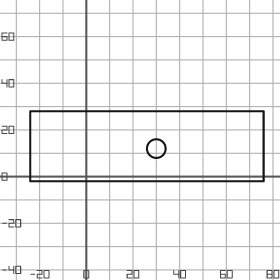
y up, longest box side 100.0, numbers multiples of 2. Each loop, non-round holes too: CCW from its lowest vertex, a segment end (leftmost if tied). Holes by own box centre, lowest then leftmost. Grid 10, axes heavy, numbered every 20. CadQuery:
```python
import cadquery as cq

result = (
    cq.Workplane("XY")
    .moveTo(-24.0, -2.0)
    .lineTo(76.0, -2.0)
    .lineTo(76.0, 28.0)
    .lineTo(-24.0, 28.0)
    .close()
    .moveTo(30.0, 12.0)
    .circle(4.0)
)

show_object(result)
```